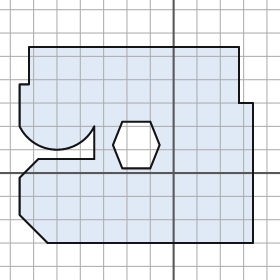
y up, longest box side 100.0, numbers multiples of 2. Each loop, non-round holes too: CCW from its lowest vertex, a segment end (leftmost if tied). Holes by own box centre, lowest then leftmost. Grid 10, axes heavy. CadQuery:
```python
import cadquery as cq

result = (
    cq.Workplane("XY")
    .moveTo(-54.0, -30.0)
    .lineTo(34.0, -30.0)
    .lineTo(34.0, 30.0)
    .lineTo(28.0, 30.0)
    .lineTo(28.0, 54.0)
    .lineTo(-62.0, 54.0)
    .lineTo(-62.0, 38.0)
    .lineTo(-66.0, 38.0)
    .lineTo(-66.0, 20.0)
    .threePointArc((-50.0, 10.0), (-34.0, 20.0))
    .lineTo(-34.0, 6.0)
    .lineTo(-58.0, 6.0)
    .lineTo(-66.0, -2.0)
    .lineTo(-66.0, -18.0)
    .close()
    .moveTo(-22.0, 2.0)
    .lineTo(-10.0, 2.0)
    .lineTo(-6.0, 12.0)
    .lineTo(-10.0, 22.0)
    .lineTo(-22.0, 22.0)
    .lineTo(-26.0, 12.0)
    .close()
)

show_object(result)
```